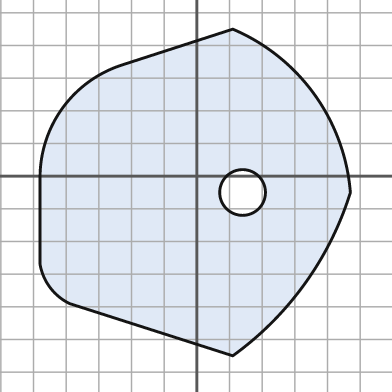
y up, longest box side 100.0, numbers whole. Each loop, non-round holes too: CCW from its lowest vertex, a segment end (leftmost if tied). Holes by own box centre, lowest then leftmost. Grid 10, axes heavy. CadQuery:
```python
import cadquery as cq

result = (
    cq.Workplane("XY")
    .moveTo(11.0, -55.0)
    .threePointArc((33.0, -33.0), (47.0, -5.0))
    .threePointArc((36.0, 25.0), (11.0, 45.0))
    .lineTo(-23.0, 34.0)
    .threePointArc((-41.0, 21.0), (-48.0, 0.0))
    .lineTo(-48.0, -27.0)
    .threePointArc((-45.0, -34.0), (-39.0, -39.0))
    .close()
    .moveTo(14.0, -5.0)
    .circle(7.0)
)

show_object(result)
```